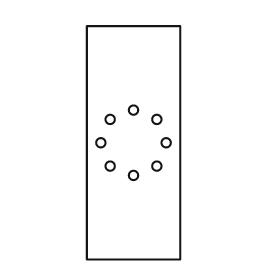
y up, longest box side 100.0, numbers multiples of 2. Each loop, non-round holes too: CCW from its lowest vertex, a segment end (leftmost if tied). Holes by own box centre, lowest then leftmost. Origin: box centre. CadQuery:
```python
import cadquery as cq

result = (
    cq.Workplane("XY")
    .moveTo(-20.0, -50.0)
    .lineTo(20.0, -50.0)
    .lineTo(20.0, 50.0)
    .lineTo(-20.0, 50.0)
    .close()
    .moveTo(0.0, -14.0)
    .circle(2.0)
    .moveTo(-10.0, -10.0)
    .circle(2.0)
    .moveTo(10.0, -10.0)
    .circle(2.0)
    .moveTo(-14.0, 0.0)
    .circle(2.0)
    .moveTo(14.0, 0.0)
    .circle(2.0)
    .moveTo(-10.0, 10.0)
    .circle(2.0)
    .moveTo(10.0, 10.0)
    .circle(2.0)
    .moveTo(0.0, 14.0)
    .circle(2.0)
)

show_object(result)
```